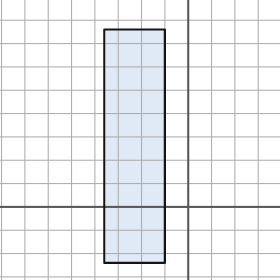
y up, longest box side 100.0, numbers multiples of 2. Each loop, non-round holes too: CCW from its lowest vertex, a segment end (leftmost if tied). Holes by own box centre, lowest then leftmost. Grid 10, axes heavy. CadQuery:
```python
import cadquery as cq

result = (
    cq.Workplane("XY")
    .moveTo(-36.0, -24.0)
    .lineTo(-10.0, -24.0)
    .lineTo(-10.0, 76.0)
    .lineTo(-36.0, 76.0)
    .close()
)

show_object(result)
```